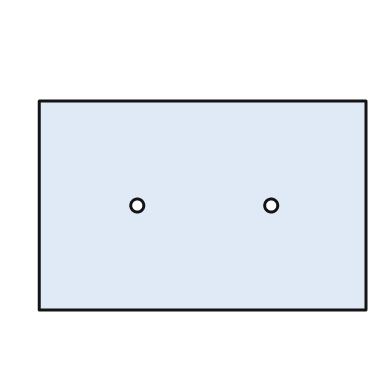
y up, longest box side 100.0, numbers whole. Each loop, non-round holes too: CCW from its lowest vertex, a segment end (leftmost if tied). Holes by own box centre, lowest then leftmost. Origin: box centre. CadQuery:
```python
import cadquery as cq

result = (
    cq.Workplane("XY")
    .moveTo(-50.0, -32.0)
    .lineTo(50.0, -32.0)
    .lineTo(50.0, 32.0)
    .lineTo(-50.0, 32.0)
    .close()
    .moveTo(-20.0, 0.0)
    .circle(2.0)
    .moveTo(21.0, 0.0)
    .circle(2.0)
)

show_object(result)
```